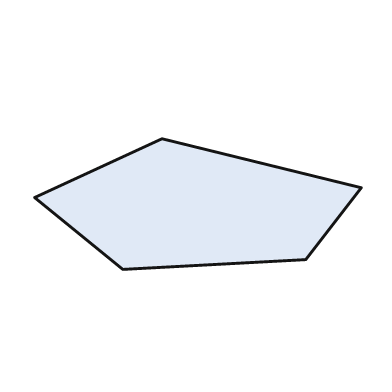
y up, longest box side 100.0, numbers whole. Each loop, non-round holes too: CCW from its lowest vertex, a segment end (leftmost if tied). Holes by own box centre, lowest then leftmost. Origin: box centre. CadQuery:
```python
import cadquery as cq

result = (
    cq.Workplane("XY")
    .moveTo(-23.0, -20.0)
    .lineTo(33.0, -17.0)
    .lineTo(50.0, 5.0)
    .lineTo(-11.0, 20.0)
    .lineTo(-50.0, 2.0)
    .close()
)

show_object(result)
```